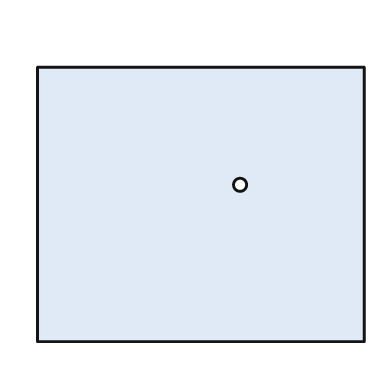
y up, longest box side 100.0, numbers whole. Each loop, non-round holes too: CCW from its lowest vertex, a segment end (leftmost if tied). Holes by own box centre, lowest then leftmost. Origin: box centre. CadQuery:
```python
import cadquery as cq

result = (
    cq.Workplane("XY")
    .moveTo(-50.0, -42.0)
    .lineTo(50.0, -42.0)
    .lineTo(50.0, 42.0)
    .lineTo(-50.0, 42.0)
    .close()
    .moveTo(12.0, 6.0)
    .circle(2.0)
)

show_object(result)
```